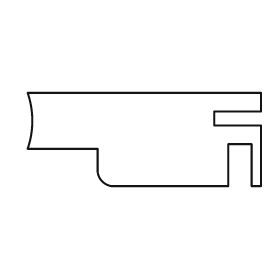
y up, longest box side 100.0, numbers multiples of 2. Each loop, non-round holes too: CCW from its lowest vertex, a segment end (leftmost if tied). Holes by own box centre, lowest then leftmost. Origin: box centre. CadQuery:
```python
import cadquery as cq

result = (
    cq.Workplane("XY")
    .moveTo(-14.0, -20.0)
    .lineTo(36.0, -20.0)
    .lineTo(36.0, -2.0)
    .lineTo(46.0, -2.0)
    .lineTo(46.0, -20.0)
    .lineTo(50.0, -20.0)
    .lineTo(50.0, 6.0)
    .lineTo(30.0, 6.0)
    .lineTo(30.0, 12.0)
    .lineTo(50.0, 12.0)
    .lineTo(50.0, 20.0)
    .lineTo(-50.0, 20.0)
    .threePointArc((-48.0, 8.0), (-50.0, -4.0))
    .lineTo(-20.0, -4.0)
    .lineTo(-20.0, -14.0)
    .threePointArc((-18.0, -18.0), (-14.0, -20.0))
    .close()
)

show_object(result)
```